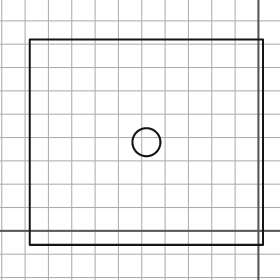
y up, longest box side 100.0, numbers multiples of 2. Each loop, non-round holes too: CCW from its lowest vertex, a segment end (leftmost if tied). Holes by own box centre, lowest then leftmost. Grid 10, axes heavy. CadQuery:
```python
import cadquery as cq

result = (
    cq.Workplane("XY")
    .moveTo(-98.0, -6.0)
    .lineTo(2.0, -6.0)
    .lineTo(2.0, 82.0)
    .lineTo(-98.0, 82.0)
    .close()
    .moveTo(-48.0, 38.0)
    .circle(6.0)
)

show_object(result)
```